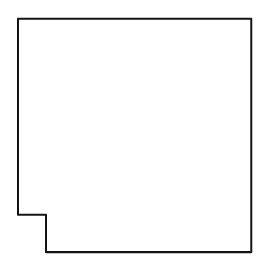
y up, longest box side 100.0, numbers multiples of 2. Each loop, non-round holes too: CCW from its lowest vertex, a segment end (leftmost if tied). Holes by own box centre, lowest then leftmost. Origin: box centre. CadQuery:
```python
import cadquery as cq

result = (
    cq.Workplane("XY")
    .moveTo(-38.0, -50.0)
    .lineTo(50.0, -50.0)
    .lineTo(50.0, 50.0)
    .lineTo(-50.0, 50.0)
    .lineTo(-50.0, -34.0)
    .lineTo(-38.0, -34.0)
    .close()
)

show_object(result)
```